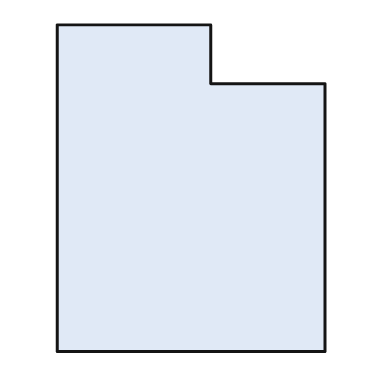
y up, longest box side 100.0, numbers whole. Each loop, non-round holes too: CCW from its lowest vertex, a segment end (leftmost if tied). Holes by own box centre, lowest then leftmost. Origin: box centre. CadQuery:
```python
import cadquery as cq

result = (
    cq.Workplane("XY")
    .moveTo(-41.0, -50.0)
    .lineTo(41.0, -50.0)
    .lineTo(41.0, 32.0)
    .lineTo(6.0, 32.0)
    .lineTo(6.0, 50.0)
    .lineTo(-41.0, 50.0)
    .close()
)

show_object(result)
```